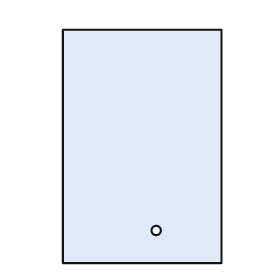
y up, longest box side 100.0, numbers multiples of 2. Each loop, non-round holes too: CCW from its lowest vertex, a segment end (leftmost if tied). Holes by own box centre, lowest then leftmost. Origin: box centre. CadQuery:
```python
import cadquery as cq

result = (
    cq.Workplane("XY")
    .moveTo(-34.0, -50.0)
    .lineTo(34.0, -50.0)
    .lineTo(34.0, 50.0)
    .lineTo(-34.0, 50.0)
    .close()
    .moveTo(6.0, -36.0)
    .circle(2.0)
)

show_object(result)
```